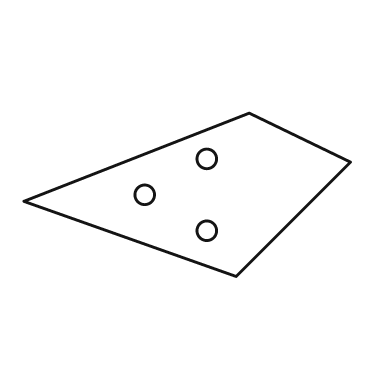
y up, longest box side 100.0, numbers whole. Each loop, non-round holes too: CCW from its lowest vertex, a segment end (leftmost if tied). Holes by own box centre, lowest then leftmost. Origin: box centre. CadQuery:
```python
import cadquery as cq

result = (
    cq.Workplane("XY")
    .moveTo(15.0, -25.0)
    .lineTo(50.0, 10.0)
    .lineTo(19.0, 25.0)
    .lineTo(-50.0, -2.0)
    .close()
    .moveTo(6.0, -11.0)
    .circle(3.0)
    .moveTo(-13.0, 0.0)
    .circle(3.0)
    .moveTo(6.0, 11.0)
    .circle(3.0)
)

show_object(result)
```